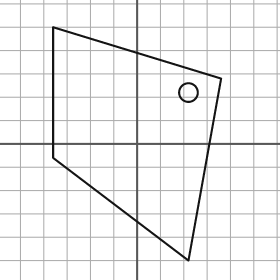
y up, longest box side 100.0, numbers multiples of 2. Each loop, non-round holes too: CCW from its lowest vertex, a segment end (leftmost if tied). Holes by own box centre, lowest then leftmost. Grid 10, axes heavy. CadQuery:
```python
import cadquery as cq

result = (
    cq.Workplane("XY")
    .moveTo(22.0, -50.0)
    .lineTo(36.0, 28.0)
    .lineTo(-36.0, 50.0)
    .lineTo(-36.0, -6.0)
    .close()
    .moveTo(22.0, 22.0)
    .circle(4.0)
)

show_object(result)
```